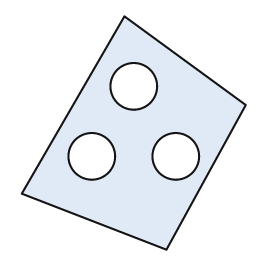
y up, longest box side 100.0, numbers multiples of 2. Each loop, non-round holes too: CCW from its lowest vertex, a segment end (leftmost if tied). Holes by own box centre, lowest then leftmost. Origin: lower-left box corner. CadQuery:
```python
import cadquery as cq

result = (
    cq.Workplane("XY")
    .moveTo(62.0, 0.0)
    .lineTo(96.0, 62.0)
    .lineTo(44.0, 100.0)
    .lineTo(0.0, 24.0)
    .close()
    .moveTo(30.0, 40.0)
    .circle(10.0)
    .moveTo(66.0, 40.0)
    .circle(10.0)
    .moveTo(48.0, 70.0)
    .circle(10.0)
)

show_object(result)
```